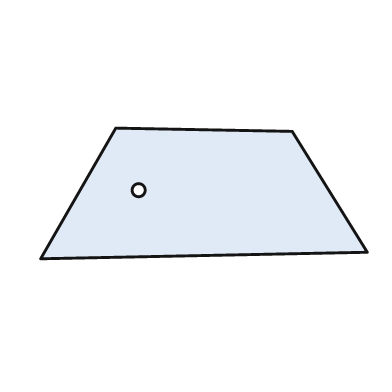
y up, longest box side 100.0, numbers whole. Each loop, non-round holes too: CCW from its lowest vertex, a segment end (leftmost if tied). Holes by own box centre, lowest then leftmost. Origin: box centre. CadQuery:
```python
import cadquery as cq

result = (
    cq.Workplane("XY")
    .moveTo(-50.0, -20.0)
    .lineTo(50.0, -18.0)
    .lineTo(27.0, 19.0)
    .lineTo(-27.0, 20.0)
    .close()
    .moveTo(-20.0, 1.0)
    .circle(2.0)
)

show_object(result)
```